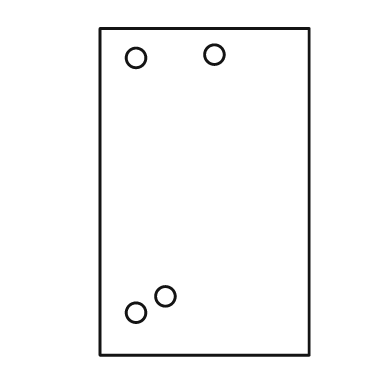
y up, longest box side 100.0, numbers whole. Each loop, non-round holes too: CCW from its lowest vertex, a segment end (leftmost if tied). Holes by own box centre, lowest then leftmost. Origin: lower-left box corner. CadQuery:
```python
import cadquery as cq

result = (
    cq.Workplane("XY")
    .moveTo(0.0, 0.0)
    .lineTo(64.0, 0.0)
    .lineTo(64.0, 100.0)
    .lineTo(0.0, 100.0)
    .close()
    .moveTo(11.0, 13.0)
    .circle(3.0)
    .moveTo(20.0, 18.0)
    .circle(3.0)
    .moveTo(11.0, 91.0)
    .circle(3.0)
    .moveTo(35.0, 92.0)
    .circle(3.0)
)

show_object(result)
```